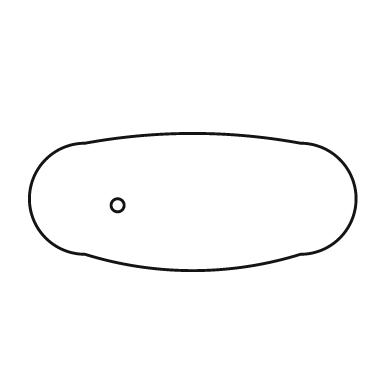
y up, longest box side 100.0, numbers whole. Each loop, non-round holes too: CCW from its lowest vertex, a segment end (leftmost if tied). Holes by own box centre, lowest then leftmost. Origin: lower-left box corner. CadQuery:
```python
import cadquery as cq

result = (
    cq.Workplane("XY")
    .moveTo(17.0, 5.0)
    .threePointArc((50.0, 0.0), (83.0, 5.0))
    .threePointArc((100.0, 22.0), (83.0, 39.0))
    .threePointArc((50.0, 42.0), (17.0, 39.0))
    .threePointArc((0.0, 22.0), (17.0, 5.0))
    .close()
    .moveTo(27.0, 20.0)
    .circle(2.0)
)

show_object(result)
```